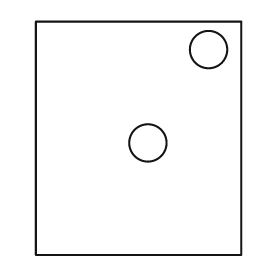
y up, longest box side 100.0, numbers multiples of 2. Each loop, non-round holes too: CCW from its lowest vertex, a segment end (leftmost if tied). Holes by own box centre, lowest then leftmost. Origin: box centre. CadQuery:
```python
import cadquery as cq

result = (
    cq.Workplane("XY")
    .moveTo(-44.0, -50.0)
    .lineTo(44.0, -50.0)
    .lineTo(44.0, 50.0)
    .lineTo(-44.0, 50.0)
    .close()
    .moveTo(4.0, -2.0)
    .circle(8.0)
    .moveTo(30.0, 38.0)
    .circle(8.0)
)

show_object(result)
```